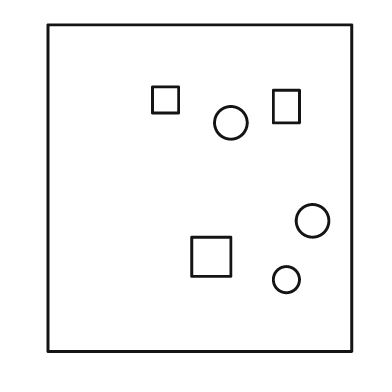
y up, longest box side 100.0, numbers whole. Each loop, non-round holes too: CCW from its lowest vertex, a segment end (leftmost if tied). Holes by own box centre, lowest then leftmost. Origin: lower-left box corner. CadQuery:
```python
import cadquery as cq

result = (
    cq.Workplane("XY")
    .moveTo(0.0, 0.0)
    .lineTo(93.0, 0.0)
    .lineTo(93.0, 100.0)
    .lineTo(0.0, 100.0)
    .close()
    .moveTo(73.0, 22.0)
    .circle(4.0)
    .moveTo(44.0, 23.0)
    .lineTo(56.0, 23.0)
    .lineTo(56.0, 35.0)
    .lineTo(44.0, 35.0)
    .close()
    .moveTo(81.0, 40.0)
    .circle(5.0)
    .moveTo(56.0, 70.0)
    .circle(5.0)
    .moveTo(69.0, 70.0)
    .lineTo(77.0, 70.0)
    .lineTo(77.0, 80.0)
    .lineTo(69.0, 80.0)
    .close()
    .moveTo(32.0, 73.0)
    .lineTo(40.0, 73.0)
    .lineTo(40.0, 81.0)
    .lineTo(32.0, 81.0)
    .close()
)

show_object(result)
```